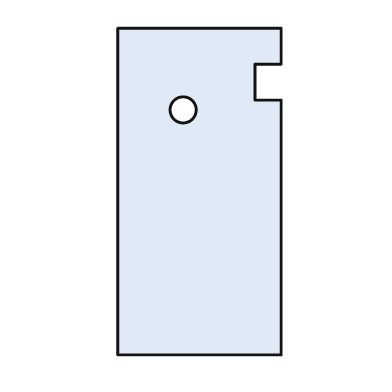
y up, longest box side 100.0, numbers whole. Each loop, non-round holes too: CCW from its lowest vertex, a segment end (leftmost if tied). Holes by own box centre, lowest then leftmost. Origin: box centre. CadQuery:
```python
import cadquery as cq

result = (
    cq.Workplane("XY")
    .moveTo(-25.0, -50.0)
    .lineTo(25.0, -50.0)
    .lineTo(25.0, 28.0)
    .lineTo(17.0, 28.0)
    .lineTo(17.0, 39.0)
    .lineTo(25.0, 39.0)
    .lineTo(25.0, 50.0)
    .lineTo(-25.0, 50.0)
    .close()
    .moveTo(-5.0, 25.0)
    .circle(4.0)
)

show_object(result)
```